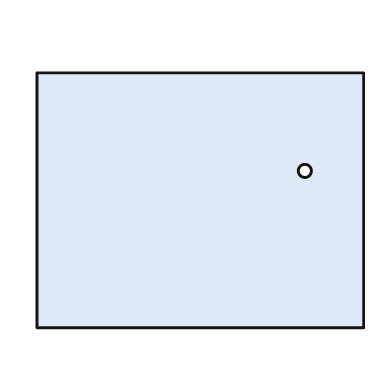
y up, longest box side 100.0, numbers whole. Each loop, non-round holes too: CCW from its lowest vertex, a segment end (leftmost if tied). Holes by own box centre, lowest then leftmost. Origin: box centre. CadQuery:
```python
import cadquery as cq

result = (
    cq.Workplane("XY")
    .moveTo(-50.0, -39.0)
    .lineTo(50.0, -39.0)
    .lineTo(50.0, 39.0)
    .lineTo(-50.0, 39.0)
    .close()
    .moveTo(32.0, 9.0)
    .circle(2.0)
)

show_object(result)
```